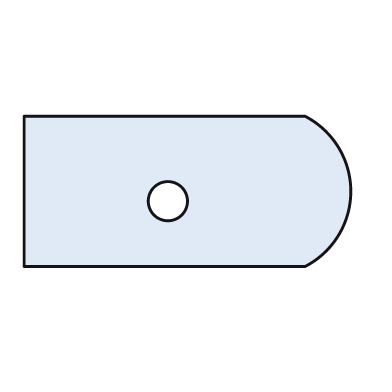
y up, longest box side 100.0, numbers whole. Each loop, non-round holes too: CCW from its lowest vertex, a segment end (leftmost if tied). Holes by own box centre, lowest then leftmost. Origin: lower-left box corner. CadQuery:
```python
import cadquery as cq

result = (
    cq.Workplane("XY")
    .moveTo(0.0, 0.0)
    .lineTo(86.0, 0.0)
    .threePointArc((100.0, 23.0), (86.0, 46.0))
    .lineTo(0.0, 46.0)
    .close()
    .moveTo(44.0, 20.0)
    .circle(6.0)
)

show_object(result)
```